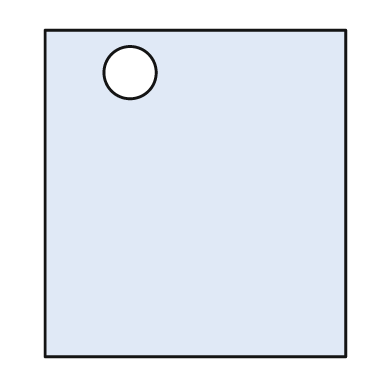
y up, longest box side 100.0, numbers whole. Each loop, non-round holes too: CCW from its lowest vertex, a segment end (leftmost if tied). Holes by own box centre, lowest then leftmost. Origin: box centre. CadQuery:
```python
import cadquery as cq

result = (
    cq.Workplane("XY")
    .moveTo(-46.0, -50.0)
    .lineTo(46.0, -50.0)
    .lineTo(46.0, 50.0)
    .lineTo(-46.0, 50.0)
    .close()
    .moveTo(-20.0, 37.0)
    .circle(8.0)
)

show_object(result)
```